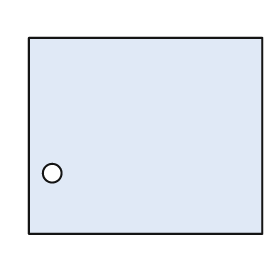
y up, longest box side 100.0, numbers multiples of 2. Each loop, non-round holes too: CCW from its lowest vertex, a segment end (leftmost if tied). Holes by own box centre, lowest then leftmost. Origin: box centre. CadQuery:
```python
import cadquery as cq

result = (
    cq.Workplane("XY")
    .moveTo(-50.0, -42.0)
    .lineTo(50.0, -42.0)
    .lineTo(50.0, 42.0)
    .lineTo(-50.0, 42.0)
    .close()
    .moveTo(-40.0, -16.0)
    .circle(4.0)
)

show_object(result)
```